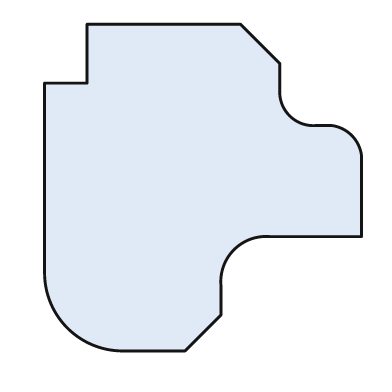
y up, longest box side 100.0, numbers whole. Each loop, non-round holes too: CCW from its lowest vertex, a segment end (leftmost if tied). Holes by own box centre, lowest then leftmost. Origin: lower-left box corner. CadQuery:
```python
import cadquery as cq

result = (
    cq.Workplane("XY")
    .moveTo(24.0, 0.0)
    .lineTo(43.0, 0.0)
    .lineTo(54.0, 11.0)
    .lineTo(54.0, 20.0)
    .threePointArc((58.0, 31.0), (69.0, 35.0))
    .lineTo(97.0, 35.0)
    .lineTo(97.0, 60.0)
    .threePointArc((94.0, 66.0), (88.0, 69.0))
    .lineTo(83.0, 69.0)
    .threePointArc((75.0, 72.0), (72.0, 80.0))
    .lineTo(72.0, 88.0)
    .lineTo(60.0, 100.0)
    .lineTo(13.0, 100.0)
    .lineTo(13.0, 82.0)
    .lineTo(0.0, 82.0)
    .lineTo(0.0, 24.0)
    .threePointArc((7.0, 7.0), (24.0, 0.0))
    .close()
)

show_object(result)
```